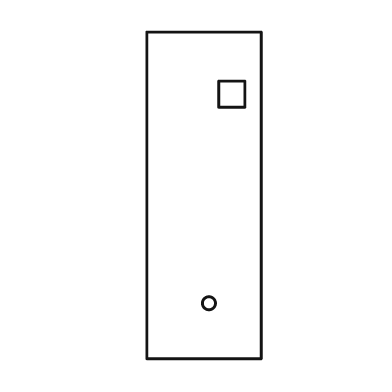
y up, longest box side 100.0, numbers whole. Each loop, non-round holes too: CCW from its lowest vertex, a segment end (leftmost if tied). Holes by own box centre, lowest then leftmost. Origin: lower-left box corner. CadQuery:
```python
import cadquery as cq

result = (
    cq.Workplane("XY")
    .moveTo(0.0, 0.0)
    .lineTo(35.0, 0.0)
    .lineTo(35.0, 100.0)
    .lineTo(0.0, 100.0)
    .close()
    .moveTo(19.0, 17.0)
    .circle(2.0)
    .moveTo(22.0, 77.0)
    .lineTo(30.0, 77.0)
    .lineTo(30.0, 85.0)
    .lineTo(22.0, 85.0)
    .close()
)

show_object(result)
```